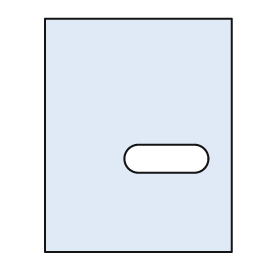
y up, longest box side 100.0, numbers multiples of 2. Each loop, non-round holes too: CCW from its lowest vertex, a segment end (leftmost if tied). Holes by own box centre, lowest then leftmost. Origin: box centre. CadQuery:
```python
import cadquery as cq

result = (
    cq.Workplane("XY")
    .moveTo(-40.0, -50.0)
    .lineTo(40.0, -50.0)
    .lineTo(40.0, 50.0)
    .lineTo(-40.0, 50.0)
    .close()
    .moveTo(0.0, -16.0)
    .lineTo(24.0, -16.0)
    .threePointArc((30.0, -10.0), (24.0, -4.0))
    .lineTo(0.0, -4.0)
    .threePointArc((-6.0, -10.0), (0.0, -16.0))
    .close()
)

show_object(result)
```